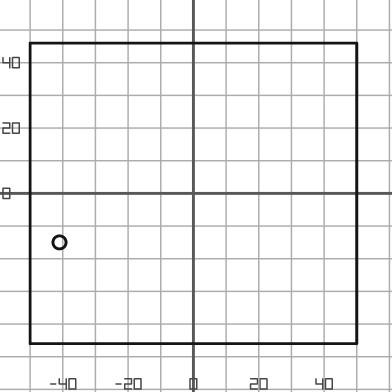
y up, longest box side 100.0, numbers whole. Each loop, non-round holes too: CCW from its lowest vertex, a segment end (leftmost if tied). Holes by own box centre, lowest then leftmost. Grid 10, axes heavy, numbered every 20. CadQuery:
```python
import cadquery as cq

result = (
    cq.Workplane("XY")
    .moveTo(-50.0, -46.0)
    .lineTo(50.0, -46.0)
    .lineTo(50.0, 46.0)
    .lineTo(-50.0, 46.0)
    .close()
    .moveTo(-41.0, -15.0)
    .circle(2.0)
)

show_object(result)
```